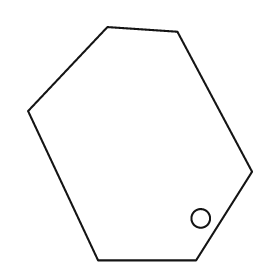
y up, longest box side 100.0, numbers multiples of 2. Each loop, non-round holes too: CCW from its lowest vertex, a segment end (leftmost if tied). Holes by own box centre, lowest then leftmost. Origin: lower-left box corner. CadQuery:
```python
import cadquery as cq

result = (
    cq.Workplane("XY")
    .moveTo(30.0, 0.0)
    .lineTo(72.0, 0.0)
    .lineTo(96.0, 38.0)
    .lineTo(64.0, 98.0)
    .lineTo(34.0, 100.0)
    .lineTo(0.0, 64.0)
    .close()
    .moveTo(74.0, 18.0)
    .circle(4.0)
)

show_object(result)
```